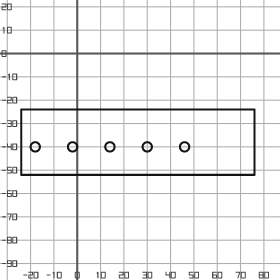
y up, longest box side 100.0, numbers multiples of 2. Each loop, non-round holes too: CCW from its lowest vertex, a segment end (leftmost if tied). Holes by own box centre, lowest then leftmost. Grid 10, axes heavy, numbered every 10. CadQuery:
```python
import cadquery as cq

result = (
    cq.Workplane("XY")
    .moveTo(-24.0, -52.0)
    .lineTo(76.0, -52.0)
    .lineTo(76.0, -24.0)
    .lineTo(-24.0, -24.0)
    .close()
    .moveTo(-18.0, -40.0)
    .circle(2.0)
    .moveTo(-2.0, -40.0)
    .circle(2.0)
    .moveTo(14.0, -40.0)
    .circle(2.0)
    .moveTo(30.0, -40.0)
    .circle(2.0)
    .moveTo(46.0, -40.0)
    .circle(2.0)
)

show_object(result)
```